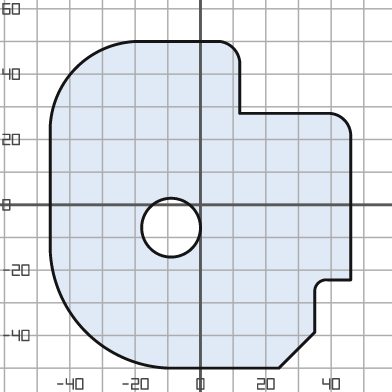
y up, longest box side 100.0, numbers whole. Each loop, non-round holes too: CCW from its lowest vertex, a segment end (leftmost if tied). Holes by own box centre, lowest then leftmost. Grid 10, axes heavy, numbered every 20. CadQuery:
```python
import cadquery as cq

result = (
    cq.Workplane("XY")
    .moveTo(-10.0, -50.0)
    .lineTo(24.0, -50.0)
    .lineTo(35.0, -39.0)
    .lineTo(35.0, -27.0)
    .threePointArc((36.0, -24.0), (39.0, -23.0))
    .lineTo(46.0, -23.0)
    .lineTo(46.0, 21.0)
    .threePointArc((44.0, 26.0), (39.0, 28.0))
    .lineTo(12.0, 28.0)
    .lineTo(12.0, 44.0)
    .threePointArc((10.0, 48.0), (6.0, 50.0))
    .lineTo(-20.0, 50.0)
    .threePointArc((-38.0, 42.0), (-46.0, 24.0))
    .lineTo(-46.0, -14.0)
    .threePointArc((-35.0, -39.0), (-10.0, -50.0))
    .close()
    .moveTo(-9.0, -7.0)
    .circle(9.0)
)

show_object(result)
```